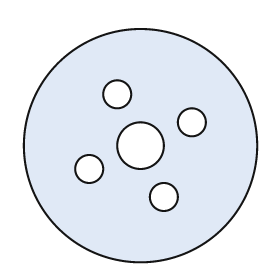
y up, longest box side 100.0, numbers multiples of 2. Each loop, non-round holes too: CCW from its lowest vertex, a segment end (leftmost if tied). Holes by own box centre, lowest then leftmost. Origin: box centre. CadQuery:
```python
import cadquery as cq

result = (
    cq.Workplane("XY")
    .moveTo(0.0, 0.0)
    .circle(50.0)
    .moveTo(10.0, -22.0)
    .circle(6.0)
    .moveTo(-22.0, -10.0)
    .circle(6.0)
    .moveTo(0.0, 0.0)
    .circle(10.0)
    .moveTo(22.0, 10.0)
    .circle(6.0)
    .moveTo(-10.0, 22.0)
    .circle(6.0)
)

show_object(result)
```